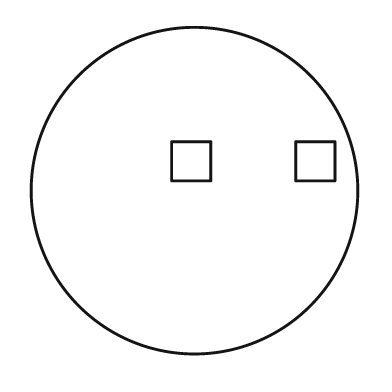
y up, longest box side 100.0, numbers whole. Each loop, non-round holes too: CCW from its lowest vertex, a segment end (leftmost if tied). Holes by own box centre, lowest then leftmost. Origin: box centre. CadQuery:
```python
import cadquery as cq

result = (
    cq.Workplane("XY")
    .moveTo(0.0, 0.0)
    .circle(50.0)
    .moveTo(-7.0, 3.0)
    .lineTo(5.0, 3.0)
    .lineTo(5.0, 15.0)
    .lineTo(-7.0, 15.0)
    .close()
    .moveTo(31.0, 3.0)
    .lineTo(43.0, 3.0)
    .lineTo(43.0, 15.0)
    .lineTo(31.0, 15.0)
    .close()
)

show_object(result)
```